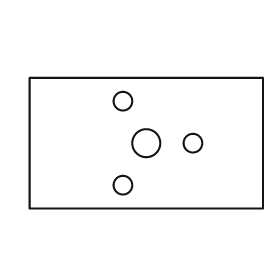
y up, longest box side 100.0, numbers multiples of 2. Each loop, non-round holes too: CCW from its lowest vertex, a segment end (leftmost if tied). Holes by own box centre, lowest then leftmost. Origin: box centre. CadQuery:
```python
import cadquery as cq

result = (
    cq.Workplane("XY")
    .moveTo(-50.0, -28.0)
    .lineTo(50.0, -28.0)
    .lineTo(50.0, 28.0)
    .lineTo(-50.0, 28.0)
    .close()
    .moveTo(-10.0, -18.0)
    .circle(4.0)
    .moveTo(0.0, 0.0)
    .circle(6.0)
    .moveTo(20.0, 0.0)
    .circle(4.0)
    .moveTo(-10.0, 18.0)
    .circle(4.0)
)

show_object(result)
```